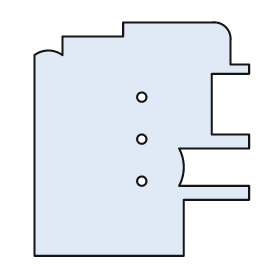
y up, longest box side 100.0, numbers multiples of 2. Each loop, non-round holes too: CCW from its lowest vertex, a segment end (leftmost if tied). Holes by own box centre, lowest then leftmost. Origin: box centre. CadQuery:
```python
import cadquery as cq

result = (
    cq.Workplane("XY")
    .moveTo(-46.0, -50.0)
    .lineTo(18.0, -50.0)
    .lineTo(18.0, -26.0)
    .lineTo(46.0, -26.0)
    .lineTo(46.0, -20.0)
    .lineTo(16.0, -20.0)
    .threePointArc((18.0, -12.0), (16.0, -4.0))
    .lineTo(46.0, -4.0)
    .lineTo(46.0, 2.0)
    .lineTo(30.0, 2.0)
    .lineTo(30.0, 28.0)
    .lineTo(46.0, 28.0)
    .lineTo(46.0, 32.0)
    .lineTo(38.0, 32.0)
    .lineTo(38.0, 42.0)
    .threePointArc((36.0, 48.0), (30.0, 50.0))
    .lineTo(-8.0, 50.0)
    .lineTo(-8.0, 44.0)
    .lineTo(-34.0, 44.0)
    .lineTo(-34.0, 36.0)
    .threePointArc((-40.0, 38.0), (-46.0, 36.0))
    .close()
    .moveTo(0.0, -18.0)
    .circle(2.0)
    .moveTo(0.0, 0.0)
    .circle(2.0)
    .moveTo(0.0, 18.0)
    .circle(2.0)
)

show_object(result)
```